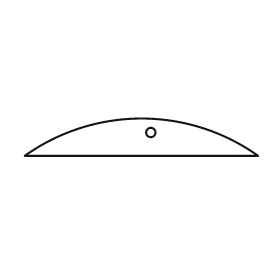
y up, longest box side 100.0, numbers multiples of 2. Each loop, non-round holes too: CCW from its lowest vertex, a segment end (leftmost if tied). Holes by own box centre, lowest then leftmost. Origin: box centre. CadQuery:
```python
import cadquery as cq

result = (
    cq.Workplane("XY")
    .moveTo(-50.0, -8.0)
    .lineTo(50.0, -8.0)
    .threePointArc((0.0, 8.0), (-50.0, -8.0))
    .close()
    .moveTo(4.0, 2.0)
    .circle(2.0)
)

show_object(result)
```